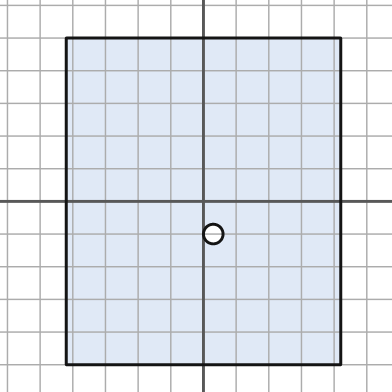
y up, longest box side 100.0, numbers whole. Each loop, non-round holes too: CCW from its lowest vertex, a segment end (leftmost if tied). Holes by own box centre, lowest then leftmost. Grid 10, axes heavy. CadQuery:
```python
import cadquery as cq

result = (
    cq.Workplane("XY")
    .moveTo(-42.0, -50.0)
    .lineTo(42.0, -50.0)
    .lineTo(42.0, 50.0)
    .lineTo(-42.0, 50.0)
    .close()
    .moveTo(3.0, -10.0)
    .circle(3.0)
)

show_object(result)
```